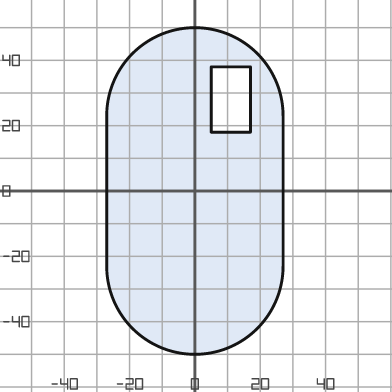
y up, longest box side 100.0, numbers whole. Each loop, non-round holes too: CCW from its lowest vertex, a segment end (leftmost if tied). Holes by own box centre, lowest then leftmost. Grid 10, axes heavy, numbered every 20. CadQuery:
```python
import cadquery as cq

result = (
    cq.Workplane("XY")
    .moveTo(-27.0, -23.0)
    .threePointArc((0.0, -50.0), (27.0, -23.0))
    .lineTo(27.0, 23.0)
    .threePointArc((0.0, 50.0), (-27.0, 23.0))
    .close()
    .moveTo(5.0, 18.0)
    .lineTo(17.0, 18.0)
    .lineTo(17.0, 38.0)
    .lineTo(5.0, 38.0)
    .close()
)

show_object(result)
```